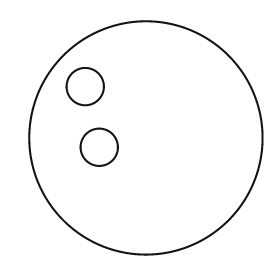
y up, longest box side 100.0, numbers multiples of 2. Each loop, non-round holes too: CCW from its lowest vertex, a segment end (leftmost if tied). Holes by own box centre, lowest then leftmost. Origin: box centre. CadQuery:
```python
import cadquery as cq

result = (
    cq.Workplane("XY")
    .moveTo(0.0, 0.0)
    .circle(50.0)
    .moveTo(-20.0, -4.0)
    .circle(8.0)
    .moveTo(-26.0, 22.0)
    .circle(8.0)
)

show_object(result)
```